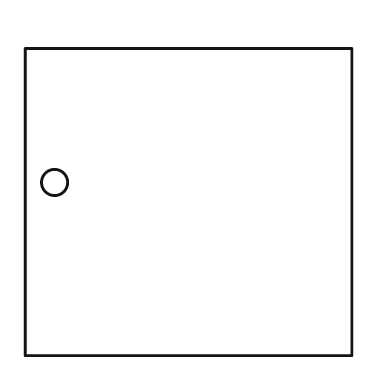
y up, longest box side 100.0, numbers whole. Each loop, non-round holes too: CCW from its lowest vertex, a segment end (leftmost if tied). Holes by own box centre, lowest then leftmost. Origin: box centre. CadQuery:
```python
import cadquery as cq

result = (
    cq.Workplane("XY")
    .moveTo(-50.0, -47.0)
    .lineTo(50.0, -47.0)
    .lineTo(50.0, 47.0)
    .lineTo(-50.0, 47.0)
    .close()
    .moveTo(-41.0, 6.0)
    .circle(4.0)
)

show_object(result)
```